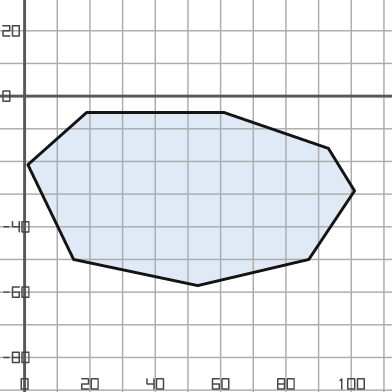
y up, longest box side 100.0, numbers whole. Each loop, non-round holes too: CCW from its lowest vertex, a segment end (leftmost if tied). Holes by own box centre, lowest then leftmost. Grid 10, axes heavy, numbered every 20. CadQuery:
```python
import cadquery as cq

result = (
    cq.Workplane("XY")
    .moveTo(53.0, -58.0)
    .lineTo(87.0, -50.0)
    .lineTo(101.0, -29.0)
    .lineTo(93.0, -16.0)
    .lineTo(61.0, -5.0)
    .lineTo(19.0, -5.0)
    .lineTo(1.0, -21.0)
    .lineTo(15.0, -50.0)
    .close()
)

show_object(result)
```